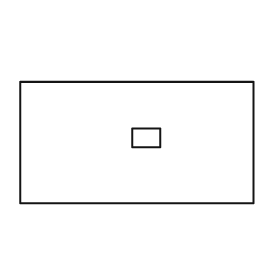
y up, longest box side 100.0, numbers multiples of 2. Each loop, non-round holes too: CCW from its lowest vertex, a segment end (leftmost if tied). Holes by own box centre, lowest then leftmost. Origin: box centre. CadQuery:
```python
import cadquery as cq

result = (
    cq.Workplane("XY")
    .moveTo(-50.0, -26.0)
    .lineTo(50.0, -26.0)
    .lineTo(50.0, 26.0)
    .lineTo(-50.0, 26.0)
    .close()
    .moveTo(-2.0, -2.0)
    .lineTo(10.0, -2.0)
    .lineTo(10.0, 6.0)
    .lineTo(-2.0, 6.0)
    .close()
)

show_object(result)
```